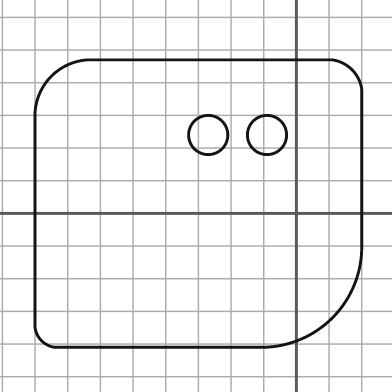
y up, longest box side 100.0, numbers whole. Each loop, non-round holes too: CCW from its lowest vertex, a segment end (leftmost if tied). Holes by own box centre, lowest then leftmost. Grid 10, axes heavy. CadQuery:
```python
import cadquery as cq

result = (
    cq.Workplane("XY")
    .moveTo(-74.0, -41.0)
    .lineTo(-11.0, -41.0)
    .threePointArc((11.0, -32.0), (20.0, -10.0))
    .lineTo(20.0, 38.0)
    .threePointArc((17.0, 44.0), (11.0, 47.0))
    .lineTo(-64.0, 47.0)
    .threePointArc((-75.0, 42.0), (-80.0, 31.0))
    .lineTo(-80.0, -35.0)
    .threePointArc((-78.0, -39.0), (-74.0, -41.0))
    .close()
    .moveTo(-27.0, 24.0)
    .circle(6.0)
    .moveTo(-9.0, 24.0)
    .circle(6.0)
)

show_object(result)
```